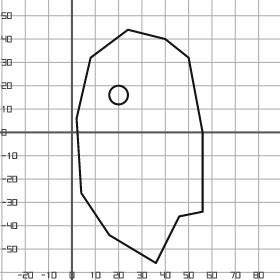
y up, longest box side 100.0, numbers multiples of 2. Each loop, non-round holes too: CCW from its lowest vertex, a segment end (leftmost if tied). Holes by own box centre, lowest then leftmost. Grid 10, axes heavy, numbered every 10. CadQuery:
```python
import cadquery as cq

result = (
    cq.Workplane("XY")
    .moveTo(36.0, -56.0)
    .lineTo(46.0, -36.0)
    .lineTo(56.0, -34.0)
    .lineTo(56.0, 0.0)
    .lineTo(50.0, 32.0)
    .lineTo(40.0, 40.0)
    .lineTo(24.0, 44.0)
    .lineTo(8.0, 32.0)
    .lineTo(2.0, 6.0)
    .lineTo(4.0, -26.0)
    .lineTo(16.0, -44.0)
    .close()
    .moveTo(20.0, 16.0)
    .circle(4.0)
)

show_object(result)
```